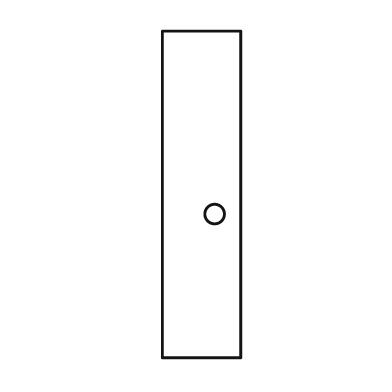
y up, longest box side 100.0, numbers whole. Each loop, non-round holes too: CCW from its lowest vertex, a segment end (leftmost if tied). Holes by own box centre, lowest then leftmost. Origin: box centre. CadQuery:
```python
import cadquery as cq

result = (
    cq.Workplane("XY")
    .moveTo(-12.0, -50.0)
    .lineTo(12.0, -50.0)
    .lineTo(12.0, 50.0)
    .lineTo(-12.0, 50.0)
    .close()
    .moveTo(4.0, -6.0)
    .circle(3.0)
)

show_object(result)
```